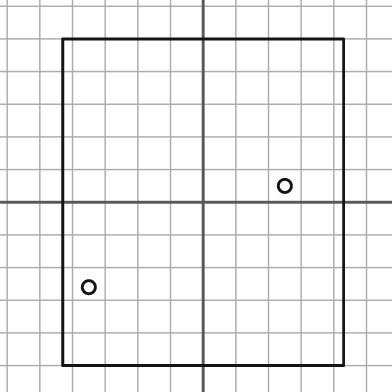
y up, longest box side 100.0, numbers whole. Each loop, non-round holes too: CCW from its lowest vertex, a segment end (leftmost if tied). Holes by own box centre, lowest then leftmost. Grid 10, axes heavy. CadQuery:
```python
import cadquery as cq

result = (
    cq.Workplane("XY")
    .moveTo(-43.0, -50.0)
    .lineTo(43.0, -50.0)
    .lineTo(43.0, 50.0)
    .lineTo(-43.0, 50.0)
    .close()
    .moveTo(-35.0, -26.0)
    .circle(2.0)
    .moveTo(25.0, 5.0)
    .circle(2.0)
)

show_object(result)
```